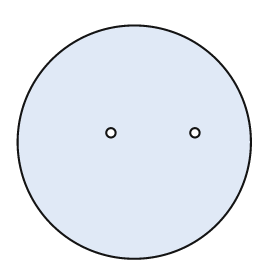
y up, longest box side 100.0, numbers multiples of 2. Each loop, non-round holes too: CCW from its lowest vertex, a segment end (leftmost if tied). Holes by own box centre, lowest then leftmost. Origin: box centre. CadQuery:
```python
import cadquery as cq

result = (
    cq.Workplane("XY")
    .moveTo(0.0, 0.0)
    .circle(50.0)
    .moveTo(-10.0, 4.0)
    .circle(2.0)
    .moveTo(26.0, 4.0)
    .circle(2.0)
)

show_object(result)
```